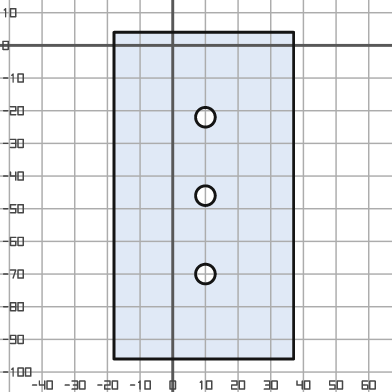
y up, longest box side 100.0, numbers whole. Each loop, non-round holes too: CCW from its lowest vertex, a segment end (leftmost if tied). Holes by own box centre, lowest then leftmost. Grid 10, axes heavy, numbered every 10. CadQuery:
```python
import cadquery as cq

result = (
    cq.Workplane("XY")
    .moveTo(-18.0, -96.0)
    .lineTo(37.0, -96.0)
    .lineTo(37.0, 4.0)
    .lineTo(-18.0, 4.0)
    .close()
    .moveTo(10.0, -70.0)
    .circle(3.0)
    .moveTo(10.0, -46.0)
    .circle(3.0)
    .moveTo(10.0, -22.0)
    .circle(3.0)
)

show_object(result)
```